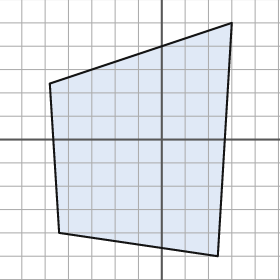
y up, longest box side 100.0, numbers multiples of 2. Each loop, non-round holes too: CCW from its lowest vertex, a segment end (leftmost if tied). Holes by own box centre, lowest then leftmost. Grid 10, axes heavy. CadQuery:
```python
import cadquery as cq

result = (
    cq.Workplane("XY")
    .moveTo(24.0, -50.0)
    .lineTo(30.0, 50.0)
    .lineTo(-48.0, 24.0)
    .lineTo(-44.0, -40.0)
    .close()
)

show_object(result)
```